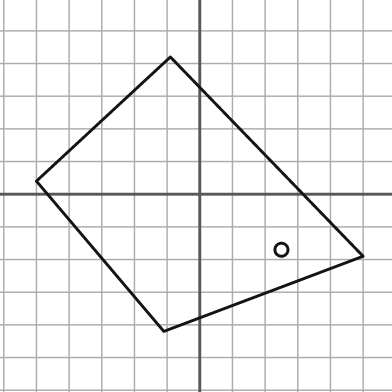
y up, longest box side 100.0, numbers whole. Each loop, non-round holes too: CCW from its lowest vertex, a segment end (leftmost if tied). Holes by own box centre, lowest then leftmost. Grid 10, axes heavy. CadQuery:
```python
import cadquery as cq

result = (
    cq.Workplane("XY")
    .moveTo(-11.0, -42.0)
    .lineTo(50.0, -19.0)
    .lineTo(-9.0, 42.0)
    .lineTo(-50.0, 4.0)
    .close()
    .moveTo(25.0, -17.0)
    .circle(2.0)
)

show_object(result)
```